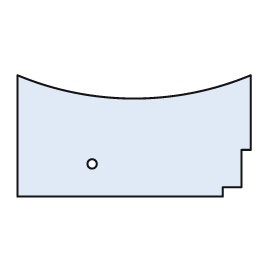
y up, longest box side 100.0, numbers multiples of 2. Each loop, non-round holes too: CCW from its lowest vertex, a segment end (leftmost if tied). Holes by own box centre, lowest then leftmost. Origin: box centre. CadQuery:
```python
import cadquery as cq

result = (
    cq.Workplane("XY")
    .moveTo(-50.0, -26.0)
    .lineTo(38.0, -26.0)
    .lineTo(38.0, -22.0)
    .lineTo(46.0, -22.0)
    .lineTo(46.0, -6.0)
    .lineTo(50.0, -6.0)
    .lineTo(50.0, 26.0)
    .threePointArc((0.0, 16.0), (-50.0, 26.0))
    .close()
    .moveTo(-18.0, -12.0)
    .circle(2.0)
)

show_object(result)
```